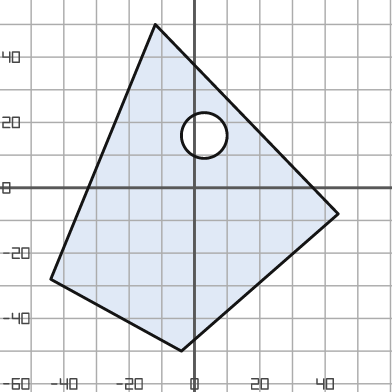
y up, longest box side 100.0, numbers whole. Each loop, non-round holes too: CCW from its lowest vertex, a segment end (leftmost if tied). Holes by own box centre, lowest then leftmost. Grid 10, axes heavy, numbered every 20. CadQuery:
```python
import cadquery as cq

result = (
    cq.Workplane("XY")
    .moveTo(-4.0, -50.0)
    .lineTo(44.0, -8.0)
    .lineTo(-12.0, 50.0)
    .lineTo(-44.0, -28.0)
    .close()
    .moveTo(3.0, 16.0)
    .circle(7.0)
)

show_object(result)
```